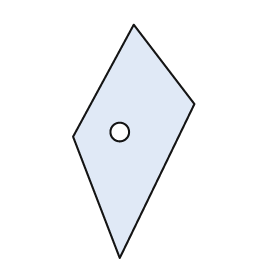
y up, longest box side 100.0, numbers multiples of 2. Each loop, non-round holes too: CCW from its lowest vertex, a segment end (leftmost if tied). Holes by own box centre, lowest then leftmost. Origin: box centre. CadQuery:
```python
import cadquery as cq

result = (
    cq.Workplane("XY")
    .moveTo(-6.0, -50.0)
    .lineTo(26.0, 16.0)
    .lineTo(0.0, 50.0)
    .lineTo(-26.0, 2.0)
    .close()
    .moveTo(-6.0, 4.0)
    .circle(4.0)
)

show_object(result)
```